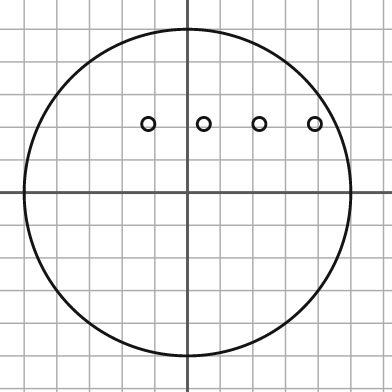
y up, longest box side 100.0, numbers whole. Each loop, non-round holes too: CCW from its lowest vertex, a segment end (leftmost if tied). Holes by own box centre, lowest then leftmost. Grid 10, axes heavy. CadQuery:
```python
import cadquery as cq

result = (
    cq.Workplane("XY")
    .moveTo(0.0, 0.0)
    .circle(50.0)
    .moveTo(-12.0, 21.0)
    .circle(2.0)
    .moveTo(5.0, 21.0)
    .circle(2.0)
    .moveTo(22.0, 21.0)
    .circle(2.0)
    .moveTo(39.0, 21.0)
    .circle(2.0)
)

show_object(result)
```